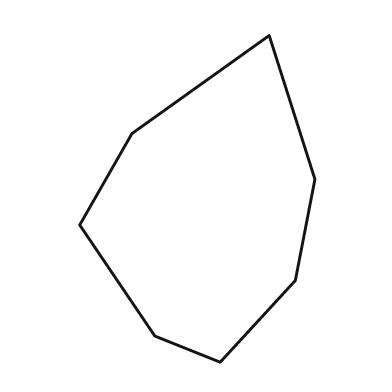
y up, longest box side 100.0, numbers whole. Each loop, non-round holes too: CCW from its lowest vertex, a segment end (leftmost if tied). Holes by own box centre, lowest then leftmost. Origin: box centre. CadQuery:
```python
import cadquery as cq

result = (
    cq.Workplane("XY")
    .moveTo(7.0, -50.0)
    .lineTo(30.0, -25.0)
    .lineTo(36.0, 6.0)
    .lineTo(22.0, 50.0)
    .lineTo(-20.0, 20.0)
    .lineTo(-36.0, -8.0)
    .lineTo(-13.0, -42.0)
    .close()
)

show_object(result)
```